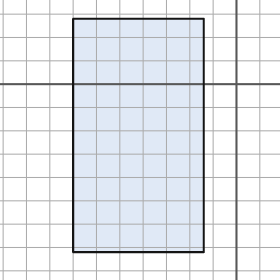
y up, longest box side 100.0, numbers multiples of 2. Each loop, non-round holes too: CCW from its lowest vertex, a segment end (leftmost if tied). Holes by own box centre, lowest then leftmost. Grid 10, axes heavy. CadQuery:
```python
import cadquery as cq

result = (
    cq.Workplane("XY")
    .moveTo(-70.0, -72.0)
    .lineTo(-14.0, -72.0)
    .lineTo(-14.0, 28.0)
    .lineTo(-70.0, 28.0)
    .close()
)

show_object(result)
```